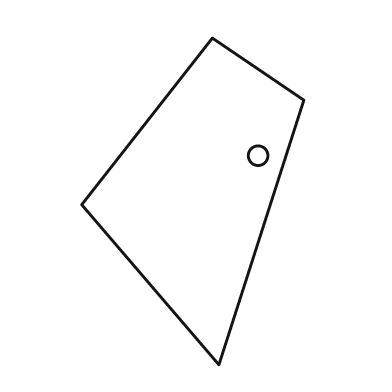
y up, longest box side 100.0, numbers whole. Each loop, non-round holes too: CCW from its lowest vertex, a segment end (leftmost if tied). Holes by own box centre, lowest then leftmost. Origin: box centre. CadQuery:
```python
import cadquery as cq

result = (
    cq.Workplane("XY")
    .moveTo(8.0, -50.0)
    .lineTo(34.0, 31.0)
    .lineTo(6.0, 50.0)
    .lineTo(-34.0, -1.0)
    .close()
    .moveTo(20.0, 14.0)
    .circle(3.0)
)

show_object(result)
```